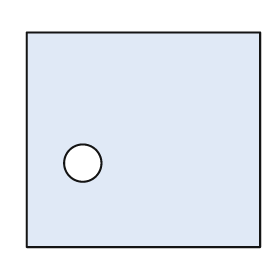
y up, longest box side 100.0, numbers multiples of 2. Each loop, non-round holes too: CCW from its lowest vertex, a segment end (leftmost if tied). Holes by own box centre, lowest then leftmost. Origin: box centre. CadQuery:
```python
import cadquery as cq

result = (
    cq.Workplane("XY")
    .moveTo(-50.0, -46.0)
    .lineTo(50.0, -46.0)
    .lineTo(50.0, 46.0)
    .lineTo(-50.0, 46.0)
    .close()
    .moveTo(-26.0, -10.0)
    .circle(8.0)
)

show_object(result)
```